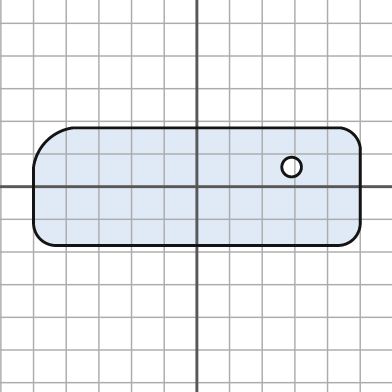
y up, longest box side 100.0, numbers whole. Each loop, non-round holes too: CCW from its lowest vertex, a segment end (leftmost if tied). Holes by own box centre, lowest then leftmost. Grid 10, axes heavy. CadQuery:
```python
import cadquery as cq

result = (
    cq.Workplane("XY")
    .moveTo(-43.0, -18.0)
    .lineTo(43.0, -18.0)
    .threePointArc((48.0, -16.0), (50.0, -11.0))
    .lineTo(50.0, 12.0)
    .threePointArc((48.0, 16.0), (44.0, 18.0))
    .lineTo(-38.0, 18.0)
    .threePointArc((-46.0, 14.0), (-50.0, 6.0))
    .lineTo(-50.0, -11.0)
    .threePointArc((-48.0, -16.0), (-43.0, -18.0))
    .close()
    .moveTo(29.0, 6.0)
    .circle(3.0)
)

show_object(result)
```